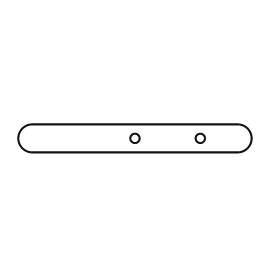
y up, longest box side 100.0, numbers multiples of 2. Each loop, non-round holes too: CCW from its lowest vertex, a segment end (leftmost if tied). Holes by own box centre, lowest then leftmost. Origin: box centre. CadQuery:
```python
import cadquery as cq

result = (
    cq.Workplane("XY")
    .moveTo(-44.0, -6.0)
    .lineTo(44.0, -6.0)
    .threePointArc((50.0, 0.0), (44.0, 6.0))
    .lineTo(-44.0, 6.0)
    .threePointArc((-50.0, 0.0), (-44.0, -6.0))
    .close()
    .moveTo(0.0, 0.0)
    .circle(2.0)
    .moveTo(28.0, 0.0)
    .circle(2.0)
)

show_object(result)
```